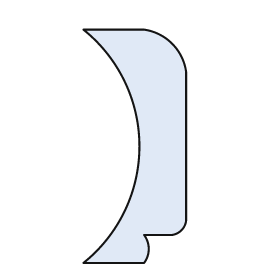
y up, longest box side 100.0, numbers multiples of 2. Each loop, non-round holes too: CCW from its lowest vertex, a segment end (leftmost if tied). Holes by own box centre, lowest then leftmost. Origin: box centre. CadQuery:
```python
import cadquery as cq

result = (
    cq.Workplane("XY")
    .moveTo(-22.0, -50.0)
    .lineTo(4.0, -50.0)
    .threePointArc((6.0, -44.0), (4.0, -38.0))
    .lineTo(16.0, -38.0)
    .threePointArc((20.0, -36.0), (22.0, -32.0))
    .lineTo(22.0, 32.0)
    .threePointArc((16.0, 44.0), (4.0, 50.0))
    .lineTo(-22.0, 50.0)
    .threePointArc((2.0, 0.0), (-22.0, -50.0))
    .close()
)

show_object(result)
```